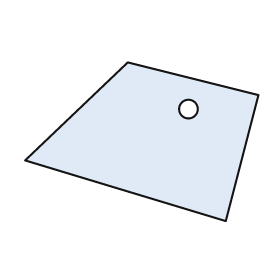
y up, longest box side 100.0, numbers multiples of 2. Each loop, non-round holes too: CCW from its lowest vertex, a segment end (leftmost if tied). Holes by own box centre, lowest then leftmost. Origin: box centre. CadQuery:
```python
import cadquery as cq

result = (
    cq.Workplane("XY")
    .moveTo(36.0, -34.0)
    .lineTo(50.0, 20.0)
    .lineTo(-6.0, 34.0)
    .lineTo(-50.0, -8.0)
    .close()
    .moveTo(20.0, 14.0)
    .circle(4.0)
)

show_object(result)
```